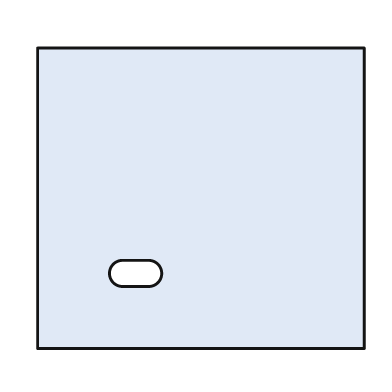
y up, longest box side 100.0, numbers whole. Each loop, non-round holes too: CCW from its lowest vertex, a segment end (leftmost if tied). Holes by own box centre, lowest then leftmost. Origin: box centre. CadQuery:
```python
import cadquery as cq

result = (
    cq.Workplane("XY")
    .moveTo(-50.0, -46.0)
    .lineTo(50.0, -46.0)
    .lineTo(50.0, 46.0)
    .lineTo(-50.0, 46.0)
    .close()
    .moveTo(-24.0, -27.0)
    .lineTo(-16.0, -27.0)
    .threePointArc((-12.0, -23.0), (-16.0, -19.0))
    .lineTo(-24.0, -19.0)
    .threePointArc((-28.0, -23.0), (-24.0, -27.0))
    .close()
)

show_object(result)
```